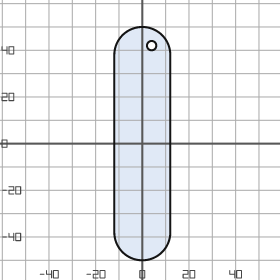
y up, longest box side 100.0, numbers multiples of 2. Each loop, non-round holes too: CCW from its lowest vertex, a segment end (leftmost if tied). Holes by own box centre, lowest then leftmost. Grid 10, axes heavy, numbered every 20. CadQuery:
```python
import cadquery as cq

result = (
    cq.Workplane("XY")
    .moveTo(-12.0, -38.0)
    .threePointArc((0.0, -50.0), (12.0, -38.0))
    .lineTo(12.0, 38.0)
    .threePointArc((0.0, 50.0), (-12.0, 38.0))
    .close()
    .moveTo(4.0, 42.0)
    .circle(2.0)
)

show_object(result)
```